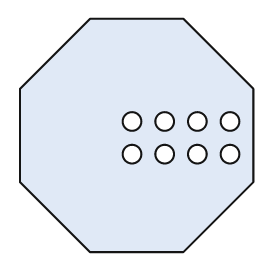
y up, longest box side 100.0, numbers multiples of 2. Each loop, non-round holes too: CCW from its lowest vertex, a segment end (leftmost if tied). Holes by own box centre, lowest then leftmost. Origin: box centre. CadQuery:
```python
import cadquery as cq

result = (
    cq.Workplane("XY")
    .moveTo(-20.0, -50.0)
    .lineTo(20.0, -50.0)
    .lineTo(50.0, -20.0)
    .lineTo(50.0, 20.0)
    .lineTo(20.0, 50.0)
    .lineTo(-20.0, 50.0)
    .lineTo(-50.0, 20.0)
    .lineTo(-50.0, -20.0)
    .close()
    .moveTo(-2.0, -8.0)
    .circle(4.0)
    .moveTo(12.0, -8.0)
    .circle(4.0)
    .moveTo(26.0, -8.0)
    .circle(4.0)
    .moveTo(40.0, -8.0)
    .circle(4.0)
    .moveTo(-2.0, 6.0)
    .circle(4.0)
    .moveTo(12.0, 6.0)
    .circle(4.0)
    .moveTo(26.0, 6.0)
    .circle(4.0)
    .moveTo(40.0, 6.0)
    .circle(4.0)
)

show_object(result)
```